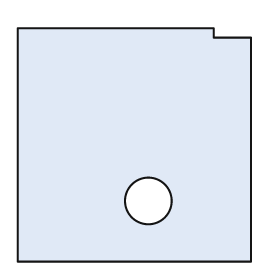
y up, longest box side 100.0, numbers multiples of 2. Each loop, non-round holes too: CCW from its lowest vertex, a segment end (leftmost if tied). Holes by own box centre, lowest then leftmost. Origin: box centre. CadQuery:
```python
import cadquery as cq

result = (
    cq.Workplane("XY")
    .moveTo(-50.0, -50.0)
    .lineTo(50.0, -50.0)
    .lineTo(50.0, 46.0)
    .lineTo(34.0, 46.0)
    .lineTo(34.0, 50.0)
    .lineTo(-50.0, 50.0)
    .close()
    .moveTo(6.0, -24.0)
    .circle(10.0)
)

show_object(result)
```